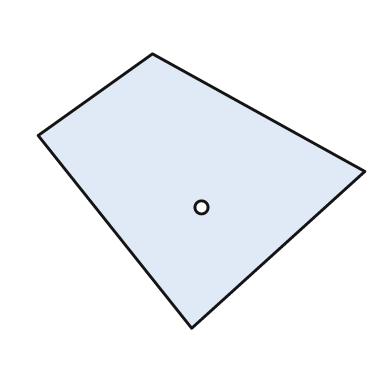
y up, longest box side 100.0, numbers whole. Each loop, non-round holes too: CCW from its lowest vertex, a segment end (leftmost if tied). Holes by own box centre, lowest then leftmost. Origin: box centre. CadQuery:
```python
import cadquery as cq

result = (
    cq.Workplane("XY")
    .moveTo(-3.0, -42.0)
    .lineTo(50.0, 6.0)
    .lineTo(-15.0, 42.0)
    .lineTo(-50.0, 17.0)
    .close()
    .moveTo(0.0, -5.0)
    .circle(2.0)
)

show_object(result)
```